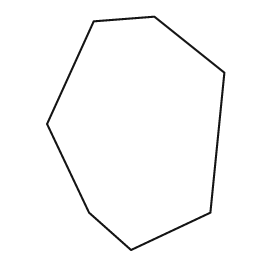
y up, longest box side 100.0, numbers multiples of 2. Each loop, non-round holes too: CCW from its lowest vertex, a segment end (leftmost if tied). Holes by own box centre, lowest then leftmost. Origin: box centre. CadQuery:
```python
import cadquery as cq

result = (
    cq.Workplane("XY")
    .moveTo(-2.0, -50.0)
    .lineTo(32.0, -34.0)
    .lineTo(38.0, 26.0)
    .lineTo(8.0, 50.0)
    .lineTo(-18.0, 48.0)
    .lineTo(-38.0, 4.0)
    .lineTo(-20.0, -34.0)
    .close()
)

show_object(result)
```